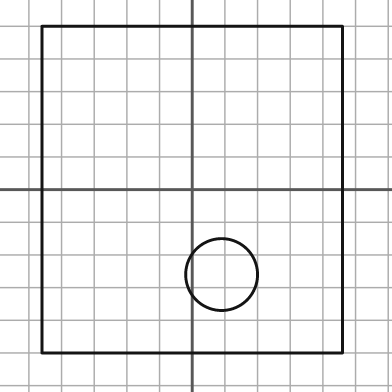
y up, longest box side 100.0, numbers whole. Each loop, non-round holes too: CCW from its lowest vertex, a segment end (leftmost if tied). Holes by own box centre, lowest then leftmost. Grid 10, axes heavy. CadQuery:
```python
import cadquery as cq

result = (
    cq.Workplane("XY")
    .moveTo(-46.0, -50.0)
    .lineTo(46.0, -50.0)
    .lineTo(46.0, 50.0)
    .lineTo(-46.0, 50.0)
    .close()
    .moveTo(9.0, -26.0)
    .circle(11.0)
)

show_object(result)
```